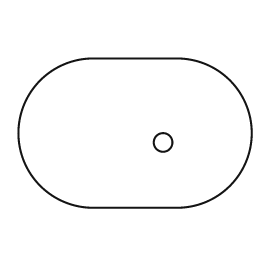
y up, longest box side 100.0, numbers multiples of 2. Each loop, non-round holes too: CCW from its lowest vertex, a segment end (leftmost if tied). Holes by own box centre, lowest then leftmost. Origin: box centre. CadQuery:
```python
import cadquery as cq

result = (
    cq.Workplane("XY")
    .moveTo(-18.0, -32.0)
    .lineTo(18.0, -32.0)
    .threePointArc((50.0, 0.0), (18.0, 32.0))
    .lineTo(-18.0, 32.0)
    .threePointArc((-50.0, 0.0), (-18.0, -32.0))
    .close()
    .moveTo(12.0, -4.0)
    .circle(4.0)
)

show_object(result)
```